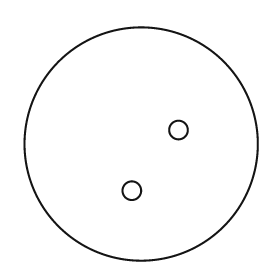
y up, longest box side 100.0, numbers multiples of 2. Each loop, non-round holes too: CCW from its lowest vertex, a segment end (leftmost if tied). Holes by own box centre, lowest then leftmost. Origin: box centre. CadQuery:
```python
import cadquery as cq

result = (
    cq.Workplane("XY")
    .moveTo(0.0, 0.0)
    .circle(50.0)
    .moveTo(-4.0, -20.0)
    .circle(4.0)
    .moveTo(16.0, 6.0)
    .circle(4.0)
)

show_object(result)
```